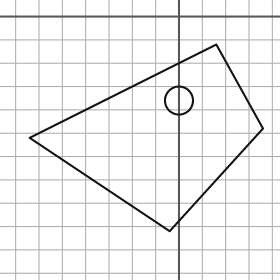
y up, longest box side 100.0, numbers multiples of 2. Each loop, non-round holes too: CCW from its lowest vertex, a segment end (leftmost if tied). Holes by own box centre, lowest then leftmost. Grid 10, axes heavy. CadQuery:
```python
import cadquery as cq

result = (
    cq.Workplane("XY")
    .moveTo(-4.0, -92.0)
    .lineTo(36.0, -48.0)
    .lineTo(16.0, -12.0)
    .lineTo(-64.0, -52.0)
    .close()
    .moveTo(0.0, -36.0)
    .circle(6.0)
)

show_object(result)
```